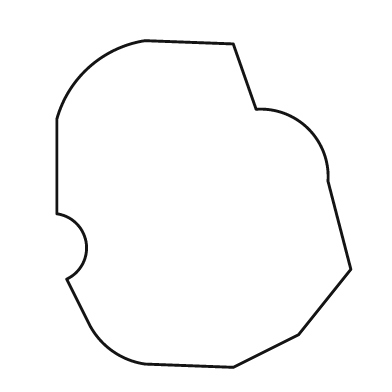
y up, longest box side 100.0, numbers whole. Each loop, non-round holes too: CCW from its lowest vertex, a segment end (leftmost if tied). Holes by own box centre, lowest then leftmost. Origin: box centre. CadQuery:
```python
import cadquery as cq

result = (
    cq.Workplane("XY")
    .moveTo(9.0, -50.0)
    .lineTo(29.0, -40.0)
    .lineTo(45.0, -20.0)
    .lineTo(38.0, 7.0)
    .threePointArc((32.0, 23.0), (16.0, 29.0))
    .lineTo(9.0, 49.0)
    .lineTo(-18.0, 50.0)
    .threePointArc((-35.0, 42.0), (-45.0, 26.0))
    .lineTo(-45.0, -3.0)
    .threePointArc((-36.0, -12.0), (-42.0, -23.0))
    .lineTo(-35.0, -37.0)
    .threePointArc((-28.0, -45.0), (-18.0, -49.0))
    .close()
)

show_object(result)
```